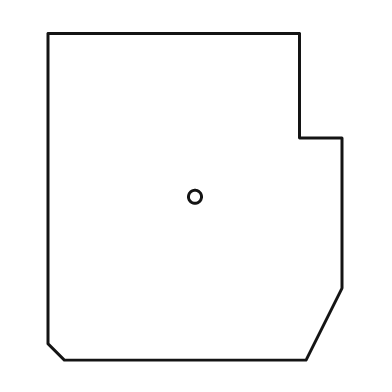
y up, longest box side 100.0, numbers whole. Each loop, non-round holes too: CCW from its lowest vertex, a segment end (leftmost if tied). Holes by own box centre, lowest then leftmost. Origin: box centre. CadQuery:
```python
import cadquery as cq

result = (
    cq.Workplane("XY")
    .moveTo(-40.0, -50.0)
    .lineTo(34.0, -50.0)
    .lineTo(45.0, -28.0)
    .lineTo(45.0, 18.0)
    .lineTo(32.0, 18.0)
    .lineTo(32.0, 50.0)
    .lineTo(-45.0, 50.0)
    .lineTo(-45.0, -45.0)
    .close()
    .moveTo(0.0, 0.0)
    .circle(2.0)
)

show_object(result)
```